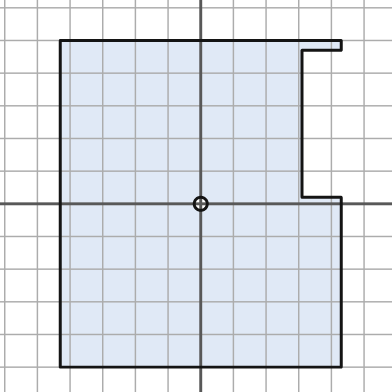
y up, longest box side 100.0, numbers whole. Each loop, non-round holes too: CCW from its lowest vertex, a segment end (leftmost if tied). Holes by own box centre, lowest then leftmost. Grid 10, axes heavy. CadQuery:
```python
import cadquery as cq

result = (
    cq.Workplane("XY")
    .moveTo(-43.0, -50.0)
    .lineTo(43.0, -50.0)
    .lineTo(43.0, 2.0)
    .lineTo(31.0, 2.0)
    .lineTo(31.0, 47.0)
    .lineTo(43.0, 47.0)
    .lineTo(43.0, 50.0)
    .lineTo(-43.0, 50.0)
    .close()
    .moveTo(0.0, 0.0)
    .circle(2.0)
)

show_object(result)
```